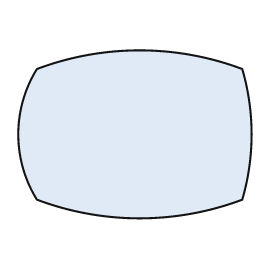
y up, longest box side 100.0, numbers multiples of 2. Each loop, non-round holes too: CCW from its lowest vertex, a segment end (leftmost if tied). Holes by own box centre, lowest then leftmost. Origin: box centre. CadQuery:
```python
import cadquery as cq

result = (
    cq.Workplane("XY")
    .moveTo(-42.0, -28.0)
    .threePointArc((2.0, -36.0), (46.0, -28.0))
    .threePointArc((50.0, 0.0), (46.0, 28.0))
    .threePointArc((2.0, 36.0), (-42.0, 28.0))
    .threePointArc((-50.0, 0.0), (-42.0, -28.0))
    .close()
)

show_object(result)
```